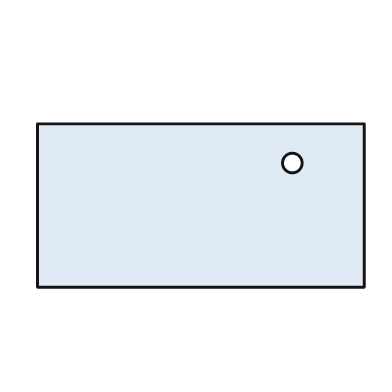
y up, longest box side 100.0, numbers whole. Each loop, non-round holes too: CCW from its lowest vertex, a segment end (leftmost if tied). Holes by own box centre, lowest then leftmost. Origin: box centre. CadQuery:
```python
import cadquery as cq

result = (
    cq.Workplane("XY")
    .moveTo(-50.0, -25.0)
    .lineTo(50.0, -25.0)
    .lineTo(50.0, 25.0)
    .lineTo(-50.0, 25.0)
    .close()
    .moveTo(28.0, 13.0)
    .circle(3.0)
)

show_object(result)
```